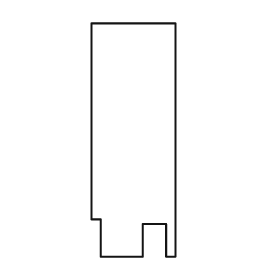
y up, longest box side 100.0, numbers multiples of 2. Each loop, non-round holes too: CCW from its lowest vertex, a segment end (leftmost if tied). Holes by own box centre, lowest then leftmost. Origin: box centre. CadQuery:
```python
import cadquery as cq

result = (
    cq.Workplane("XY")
    .moveTo(-14.0, -50.0)
    .lineTo(4.0, -50.0)
    .lineTo(4.0, -36.0)
    .lineTo(14.0, -36.0)
    .lineTo(14.0, -50.0)
    .lineTo(18.0, -50.0)
    .lineTo(18.0, 50.0)
    .lineTo(-18.0, 50.0)
    .lineTo(-18.0, -34.0)
    .lineTo(-14.0, -34.0)
    .close()
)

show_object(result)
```